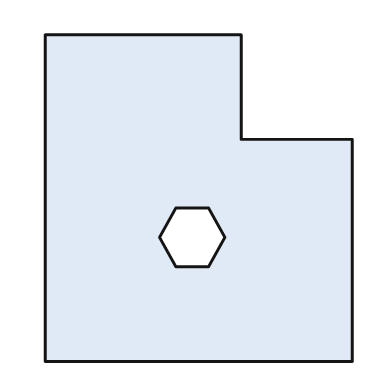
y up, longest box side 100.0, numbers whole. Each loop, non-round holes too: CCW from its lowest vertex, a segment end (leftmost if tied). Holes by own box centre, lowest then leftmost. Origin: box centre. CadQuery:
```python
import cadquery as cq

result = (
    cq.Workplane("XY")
    .moveTo(-47.0, -50.0)
    .lineTo(47.0, -50.0)
    .lineTo(47.0, 18.0)
    .lineTo(13.0, 18.0)
    .lineTo(13.0, 50.0)
    .lineTo(-47.0, 50.0)
    .close()
    .moveTo(-7.0, -21.0)
    .lineTo(3.0, -21.0)
    .lineTo(8.0, -12.0)
    .lineTo(3.0, -3.0)
    .lineTo(-7.0, -3.0)
    .lineTo(-12.0, -12.0)
    .close()
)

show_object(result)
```